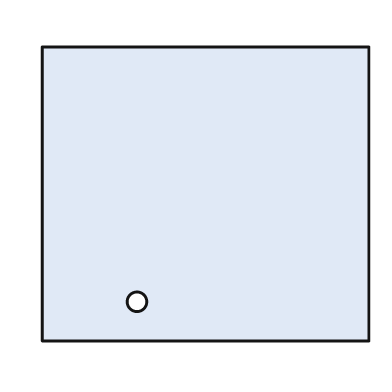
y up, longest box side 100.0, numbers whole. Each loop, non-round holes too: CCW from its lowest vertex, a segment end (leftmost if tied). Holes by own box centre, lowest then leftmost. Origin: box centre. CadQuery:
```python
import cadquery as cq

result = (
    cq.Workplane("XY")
    .moveTo(-50.0, -45.0)
    .lineTo(50.0, -45.0)
    .lineTo(50.0, 45.0)
    .lineTo(-50.0, 45.0)
    .close()
    .moveTo(-21.0, -33.0)
    .circle(3.0)
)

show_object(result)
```